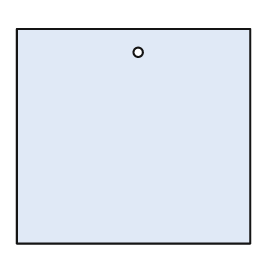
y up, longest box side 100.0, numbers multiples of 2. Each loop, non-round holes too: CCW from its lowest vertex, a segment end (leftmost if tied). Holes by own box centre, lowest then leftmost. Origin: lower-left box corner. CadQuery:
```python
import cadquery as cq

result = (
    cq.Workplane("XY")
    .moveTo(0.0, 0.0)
    .lineTo(100.0, 0.0)
    .lineTo(100.0, 92.0)
    .lineTo(0.0, 92.0)
    .close()
    .moveTo(52.0, 82.0)
    .circle(2.0)
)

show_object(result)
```